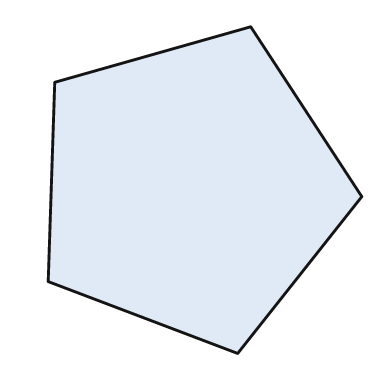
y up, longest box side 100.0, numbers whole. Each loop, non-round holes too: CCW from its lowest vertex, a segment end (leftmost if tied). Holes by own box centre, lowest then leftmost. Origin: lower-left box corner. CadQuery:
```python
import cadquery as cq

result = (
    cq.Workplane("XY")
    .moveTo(58.0, 0.0)
    .lineTo(96.0, 48.0)
    .lineTo(62.0, 100.0)
    .lineTo(2.0, 83.0)
    .lineTo(0.0, 22.0)
    .close()
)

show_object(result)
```